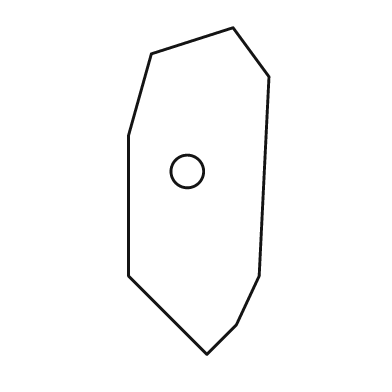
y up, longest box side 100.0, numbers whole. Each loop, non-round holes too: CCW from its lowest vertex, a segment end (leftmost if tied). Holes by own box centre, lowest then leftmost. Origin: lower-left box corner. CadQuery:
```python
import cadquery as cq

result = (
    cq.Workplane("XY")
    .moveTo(24.0, 0.0)
    .lineTo(33.0, 9.0)
    .lineTo(40.0, 24.0)
    .lineTo(43.0, 85.0)
    .lineTo(32.0, 100.0)
    .lineTo(7.0, 92.0)
    .lineTo(0.0, 67.0)
    .lineTo(0.0, 24.0)
    .close()
    .moveTo(18.0, 56.0)
    .circle(5.0)
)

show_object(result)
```